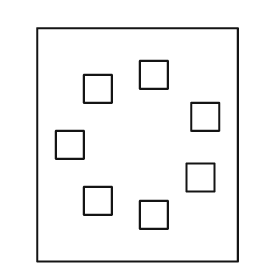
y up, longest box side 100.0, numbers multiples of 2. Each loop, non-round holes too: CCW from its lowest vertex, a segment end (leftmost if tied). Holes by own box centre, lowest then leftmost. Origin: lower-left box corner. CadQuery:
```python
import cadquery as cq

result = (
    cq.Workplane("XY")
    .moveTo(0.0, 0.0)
    .lineTo(86.0, 0.0)
    .lineTo(86.0, 100.0)
    .lineTo(0.0, 100.0)
    .close()
    .moveTo(44.0, 14.0)
    .lineTo(56.0, 14.0)
    .lineTo(56.0, 26.0)
    .lineTo(44.0, 26.0)
    .close()
    .moveTo(20.0, 20.0)
    .lineTo(32.0, 20.0)
    .lineTo(32.0, 32.0)
    .lineTo(20.0, 32.0)
    .close()
    .moveTo(64.0, 30.0)
    .lineTo(76.0, 30.0)
    .lineTo(76.0, 42.0)
    .lineTo(64.0, 42.0)
    .close()
    .moveTo(8.0, 44.0)
    .lineTo(20.0, 44.0)
    .lineTo(20.0, 56.0)
    .lineTo(8.0, 56.0)
    .close()
    .moveTo(66.0, 56.0)
    .lineTo(78.0, 56.0)
    .lineTo(78.0, 68.0)
    .lineTo(66.0, 68.0)
    .close()
    .moveTo(20.0, 68.0)
    .lineTo(32.0, 68.0)
    .lineTo(32.0, 80.0)
    .lineTo(20.0, 80.0)
    .close()
    .moveTo(44.0, 74.0)
    .lineTo(56.0, 74.0)
    .lineTo(56.0, 86.0)
    .lineTo(44.0, 86.0)
    .close()
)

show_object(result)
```